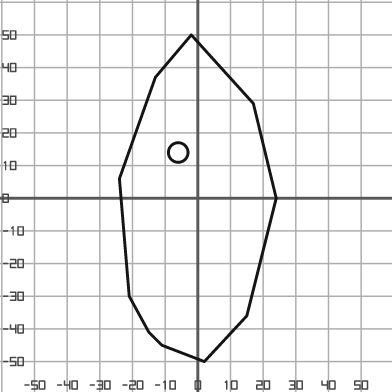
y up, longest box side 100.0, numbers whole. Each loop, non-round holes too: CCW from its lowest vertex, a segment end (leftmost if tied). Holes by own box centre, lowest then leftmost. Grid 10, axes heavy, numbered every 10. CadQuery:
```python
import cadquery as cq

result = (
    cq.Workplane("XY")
    .moveTo(2.0, -50.0)
    .lineTo(15.0, -36.0)
    .lineTo(24.0, 0.0)
    .lineTo(17.0, 29.0)
    .lineTo(-2.0, 50.0)
    .lineTo(-13.0, 37.0)
    .lineTo(-24.0, 6.0)
    .lineTo(-21.0, -30.0)
    .lineTo(-15.0, -41.0)
    .lineTo(-11.0, -45.0)
    .close()
    .moveTo(-6.0, 14.0)
    .circle(3.0)
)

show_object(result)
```